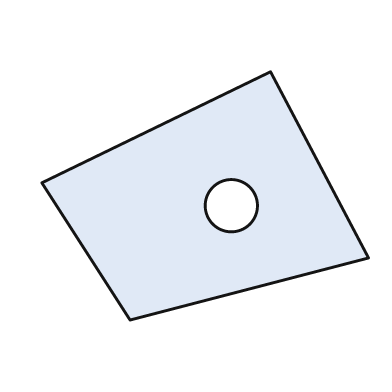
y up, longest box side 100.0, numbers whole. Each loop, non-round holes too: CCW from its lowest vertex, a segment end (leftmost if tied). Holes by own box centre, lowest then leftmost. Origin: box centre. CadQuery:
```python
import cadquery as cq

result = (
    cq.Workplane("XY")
    .moveTo(-23.0, -38.0)
    .lineTo(50.0, -19.0)
    .lineTo(20.0, 38.0)
    .lineTo(-50.0, 4.0)
    .close()
    .moveTo(8.0, -3.0)
    .circle(8.0)
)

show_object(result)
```